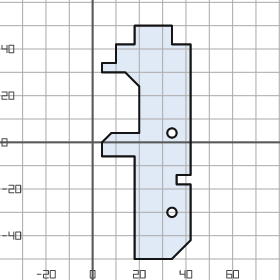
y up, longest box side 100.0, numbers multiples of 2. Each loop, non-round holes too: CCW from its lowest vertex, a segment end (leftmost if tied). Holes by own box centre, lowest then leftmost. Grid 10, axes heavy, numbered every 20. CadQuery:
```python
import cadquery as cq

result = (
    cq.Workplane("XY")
    .moveTo(18.0, -50.0)
    .lineTo(34.0, -50.0)
    .lineTo(42.0, -42.0)
    .lineTo(42.0, -18.0)
    .lineTo(36.0, -18.0)
    .lineTo(36.0, -14.0)
    .lineTo(42.0, -14.0)
    .lineTo(42.0, 42.0)
    .lineTo(34.0, 42.0)
    .lineTo(34.0, 50.0)
    .lineTo(18.0, 50.0)
    .lineTo(18.0, 42.0)
    .lineTo(10.0, 42.0)
    .lineTo(10.0, 34.0)
    .lineTo(4.0, 34.0)
    .lineTo(4.0, 30.0)
    .lineTo(14.0, 30.0)
    .lineTo(20.0, 24.0)
    .lineTo(20.0, 4.0)
    .lineTo(8.0, 4.0)
    .lineTo(4.0, 0.0)
    .lineTo(4.0, -6.0)
    .lineTo(18.0, -6.0)
    .close()
    .moveTo(34.0, -30.0)
    .circle(2.0)
    .moveTo(34.0, 4.0)
    .circle(2.0)
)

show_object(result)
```